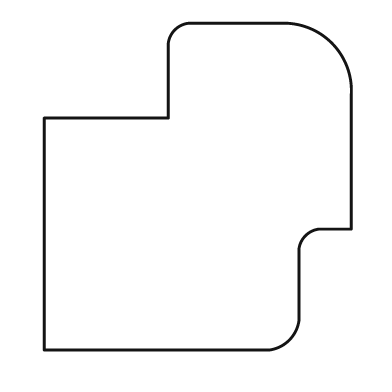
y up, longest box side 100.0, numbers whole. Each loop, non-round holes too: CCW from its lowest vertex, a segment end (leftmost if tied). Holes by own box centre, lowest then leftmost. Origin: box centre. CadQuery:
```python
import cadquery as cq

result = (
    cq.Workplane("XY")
    .moveTo(-47.0, -50.0)
    .lineTo(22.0, -50.0)
    .threePointArc((28.0, -47.0), (31.0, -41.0))
    .lineTo(31.0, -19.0)
    .threePointArc((33.0, -15.0), (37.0, -13.0))
    .lineTo(47.0, -13.0)
    .lineTo(47.0, 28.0)
    .threePointArc((41.0, 44.0), (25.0, 50.0))
    .lineTo(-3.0, 50.0)
    .threePointArc((-7.0, 48.0), (-9.0, 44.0))
    .lineTo(-9.0, 21.0)
    .lineTo(-47.0, 21.0)
    .close()
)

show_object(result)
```